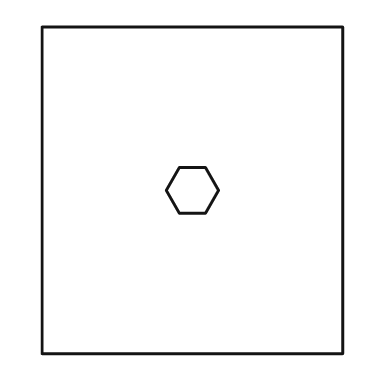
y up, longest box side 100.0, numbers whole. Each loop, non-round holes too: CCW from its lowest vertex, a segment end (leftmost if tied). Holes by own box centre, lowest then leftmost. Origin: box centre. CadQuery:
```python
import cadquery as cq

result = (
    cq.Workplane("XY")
    .moveTo(-46.0, -50.0)
    .lineTo(46.0, -50.0)
    .lineTo(46.0, 50.0)
    .lineTo(-46.0, 50.0)
    .close()
    .moveTo(-4.0, -7.0)
    .lineTo(4.0, -7.0)
    .lineTo(8.0, 0.0)
    .lineTo(4.0, 7.0)
    .lineTo(-4.0, 7.0)
    .lineTo(-8.0, 0.0)
    .close()
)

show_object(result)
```